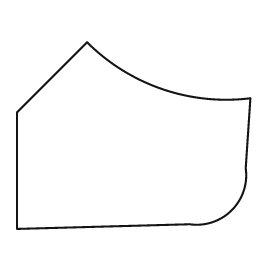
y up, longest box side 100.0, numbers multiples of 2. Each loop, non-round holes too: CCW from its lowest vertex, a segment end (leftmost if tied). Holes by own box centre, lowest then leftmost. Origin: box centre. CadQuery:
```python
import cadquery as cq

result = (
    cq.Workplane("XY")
    .moveTo(-50.0, -40.0)
    .lineTo(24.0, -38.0)
    .threePointArc((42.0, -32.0), (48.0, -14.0))
    .lineTo(50.0, 16.0)
    .threePointArc((12.0, 20.0), (-20.0, 40.0))
    .lineTo(-50.0, 10.0)
    .close()
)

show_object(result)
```